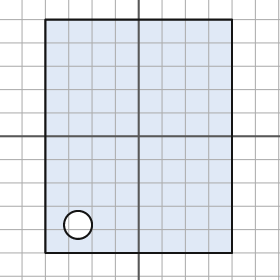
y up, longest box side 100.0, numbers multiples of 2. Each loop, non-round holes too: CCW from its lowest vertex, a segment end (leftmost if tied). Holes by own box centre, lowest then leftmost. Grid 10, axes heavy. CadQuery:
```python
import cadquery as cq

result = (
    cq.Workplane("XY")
    .moveTo(-40.0, -50.0)
    .lineTo(40.0, -50.0)
    .lineTo(40.0, 50.0)
    .lineTo(-40.0, 50.0)
    .close()
    .moveTo(-26.0, -38.0)
    .circle(6.0)
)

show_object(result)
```